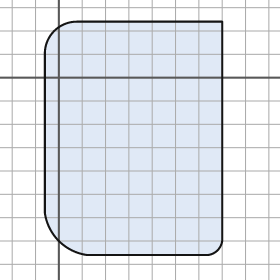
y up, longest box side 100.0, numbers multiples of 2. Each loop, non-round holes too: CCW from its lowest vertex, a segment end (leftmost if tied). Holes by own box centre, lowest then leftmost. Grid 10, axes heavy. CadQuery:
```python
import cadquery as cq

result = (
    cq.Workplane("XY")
    .moveTo(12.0, -76.0)
    .lineTo(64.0, -76.0)
    .threePointArc((68.0, -74.0), (70.0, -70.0))
    .lineTo(70.0, 24.0)
    .lineTo(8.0, 24.0)
    .threePointArc((-2.0, 20.0), (-6.0, 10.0))
    .lineTo(-6.0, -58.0)
    .threePointArc((0.0, -70.0), (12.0, -76.0))
    .close()
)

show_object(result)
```